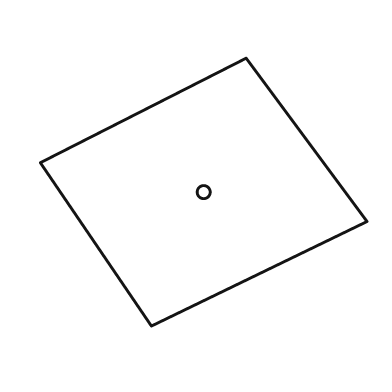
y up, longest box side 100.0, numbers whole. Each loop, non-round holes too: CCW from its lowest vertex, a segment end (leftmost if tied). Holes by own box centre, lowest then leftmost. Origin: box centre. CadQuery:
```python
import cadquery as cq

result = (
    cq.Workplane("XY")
    .moveTo(-16.0, -41.0)
    .lineTo(50.0, -9.0)
    .lineTo(13.0, 41.0)
    .lineTo(-50.0, 9.0)
    .close()
    .moveTo(0.0, 0.0)
    .circle(2.0)
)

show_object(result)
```